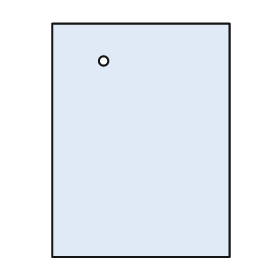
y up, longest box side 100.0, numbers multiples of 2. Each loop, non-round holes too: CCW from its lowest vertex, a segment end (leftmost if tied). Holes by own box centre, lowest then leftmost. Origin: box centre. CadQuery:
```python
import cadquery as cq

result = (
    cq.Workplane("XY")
    .moveTo(-38.0, -50.0)
    .lineTo(38.0, -50.0)
    .lineTo(38.0, 50.0)
    .lineTo(-38.0, 50.0)
    .close()
    .moveTo(-16.0, 34.0)
    .circle(2.0)
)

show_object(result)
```